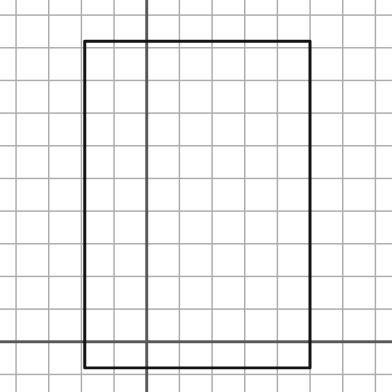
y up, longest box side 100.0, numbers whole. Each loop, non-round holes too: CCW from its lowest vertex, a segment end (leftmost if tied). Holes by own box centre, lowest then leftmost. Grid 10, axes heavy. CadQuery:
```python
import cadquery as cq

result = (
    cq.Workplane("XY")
    .moveTo(-19.0, -8.0)
    .lineTo(50.0, -8.0)
    .lineTo(50.0, 92.0)
    .lineTo(-19.0, 92.0)
    .close()
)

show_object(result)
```